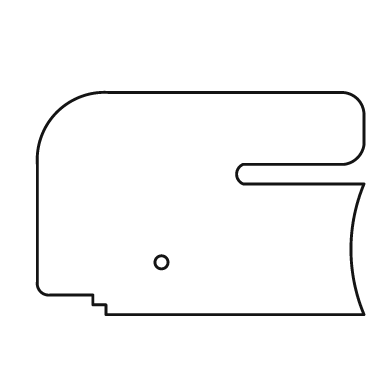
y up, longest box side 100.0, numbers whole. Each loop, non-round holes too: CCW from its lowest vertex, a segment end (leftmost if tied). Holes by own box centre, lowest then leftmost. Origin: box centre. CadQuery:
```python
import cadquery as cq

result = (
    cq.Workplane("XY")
    .moveTo(-29.0, -34.0)
    .lineTo(50.0, -34.0)
    .threePointArc((46.0, -14.0), (50.0, 6.0))
    .lineTo(13.0, 6.0)
    .threePointArc((11.0, 9.0), (13.0, 12.0))
    .lineTo(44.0, 12.0)
    .threePointArc((48.0, 14.0), (50.0, 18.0))
    .lineTo(50.0, 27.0)
    .threePointArc((48.0, 32.0), (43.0, 34.0))
    .lineTo(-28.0, 34.0)
    .threePointArc((-44.0, 28.0), (-50.0, 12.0))
    .lineTo(-50.0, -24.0)
    .threePointArc((-49.0, -27.0), (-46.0, -28.0))
    .lineTo(-33.0, -28.0)
    .lineTo(-33.0, -31.0)
    .lineTo(-29.0, -31.0)
    .close()
    .moveTo(-12.0, -18.0)
    .circle(2.0)
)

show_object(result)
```